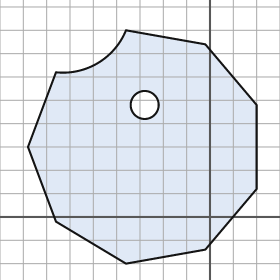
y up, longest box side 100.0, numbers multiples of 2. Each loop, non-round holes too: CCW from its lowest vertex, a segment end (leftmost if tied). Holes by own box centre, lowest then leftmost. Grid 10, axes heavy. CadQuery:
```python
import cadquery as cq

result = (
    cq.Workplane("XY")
    .moveTo(-36.0, -20.0)
    .lineTo(-2.0, -14.0)
    .lineTo(20.0, 12.0)
    .lineTo(20.0, 48.0)
    .lineTo(-2.0, 74.0)
    .lineTo(-36.0, 80.0)
    .threePointArc((-48.0, 66.0), (-66.0, 62.0))
    .lineTo(-78.0, 30.0)
    .lineTo(-66.0, -2.0)
    .close()
    .moveTo(-28.0, 48.0)
    .circle(6.0)
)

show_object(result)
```